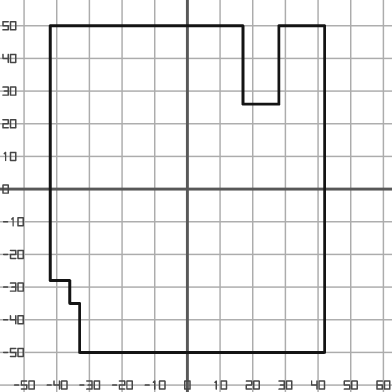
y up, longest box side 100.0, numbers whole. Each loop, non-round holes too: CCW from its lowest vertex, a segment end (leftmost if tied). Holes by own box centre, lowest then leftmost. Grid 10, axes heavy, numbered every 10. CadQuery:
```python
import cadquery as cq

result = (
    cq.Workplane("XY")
    .moveTo(-33.0, -50.0)
    .lineTo(42.0, -50.0)
    .lineTo(42.0, 50.0)
    .lineTo(28.0, 50.0)
    .lineTo(28.0, 26.0)
    .lineTo(17.0, 26.0)
    .lineTo(17.0, 50.0)
    .lineTo(-42.0, 50.0)
    .lineTo(-42.0, -28.0)
    .lineTo(-36.0, -28.0)
    .lineTo(-36.0, -35.0)
    .lineTo(-33.0, -35.0)
    .close()
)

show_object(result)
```